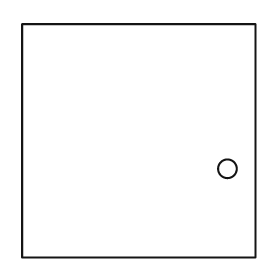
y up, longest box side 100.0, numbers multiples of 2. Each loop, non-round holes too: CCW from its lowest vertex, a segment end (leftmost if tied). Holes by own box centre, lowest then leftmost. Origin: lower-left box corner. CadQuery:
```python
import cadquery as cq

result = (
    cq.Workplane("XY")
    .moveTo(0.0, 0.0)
    .lineTo(100.0, 0.0)
    .lineTo(100.0, 100.0)
    .lineTo(0.0, 100.0)
    .close()
    .moveTo(88.0, 38.0)
    .circle(4.0)
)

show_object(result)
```